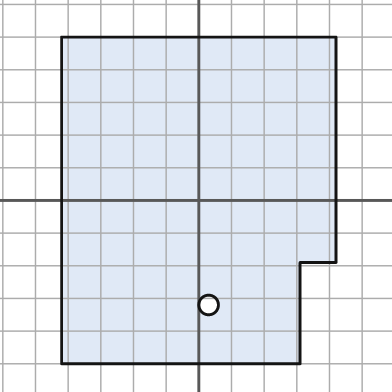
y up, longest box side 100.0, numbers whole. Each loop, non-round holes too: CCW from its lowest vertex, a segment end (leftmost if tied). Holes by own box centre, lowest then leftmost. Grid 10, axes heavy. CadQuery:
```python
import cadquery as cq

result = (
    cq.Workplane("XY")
    .moveTo(-42.0, -50.0)
    .lineTo(31.0, -50.0)
    .lineTo(31.0, -19.0)
    .lineTo(42.0, -19.0)
    .lineTo(42.0, 50.0)
    .lineTo(-42.0, 50.0)
    .close()
    .moveTo(3.0, -32.0)
    .circle(3.0)
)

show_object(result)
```